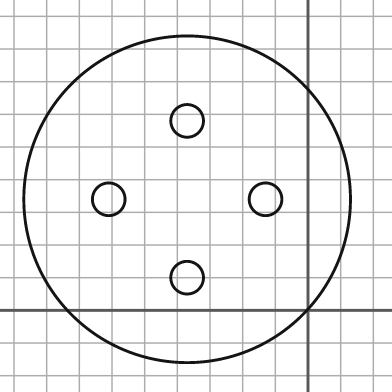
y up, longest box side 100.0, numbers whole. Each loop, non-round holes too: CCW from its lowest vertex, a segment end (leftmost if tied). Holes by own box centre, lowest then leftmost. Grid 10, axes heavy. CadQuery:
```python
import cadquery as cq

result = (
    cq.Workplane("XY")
    .moveTo(-37.0, 34.0)
    .circle(50.0)
    .moveTo(-37.0, 10.0)
    .circle(5.0)
    .moveTo(-61.0, 34.0)
    .circle(5.0)
    .moveTo(-13.0, 34.0)
    .circle(5.0)
    .moveTo(-37.0, 58.0)
    .circle(5.0)
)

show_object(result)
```